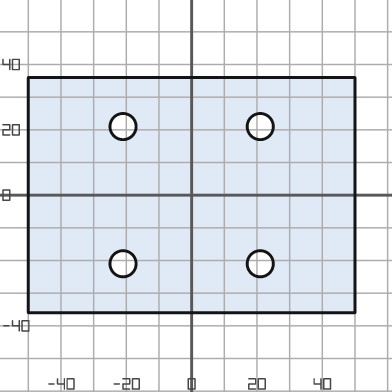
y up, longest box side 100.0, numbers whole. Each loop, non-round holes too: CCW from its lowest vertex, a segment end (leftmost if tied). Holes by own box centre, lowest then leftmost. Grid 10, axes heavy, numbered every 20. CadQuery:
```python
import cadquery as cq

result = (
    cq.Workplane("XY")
    .moveTo(-50.0, -36.0)
    .lineTo(50.0, -36.0)
    .lineTo(50.0, 36.0)
    .lineTo(-50.0, 36.0)
    .close()
    .moveTo(-21.0, -21.0)
    .circle(4.0)
    .moveTo(21.0, -21.0)
    .circle(4.0)
    .moveTo(-21.0, 21.0)
    .circle(4.0)
    .moveTo(21.0, 21.0)
    .circle(4.0)
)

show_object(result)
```